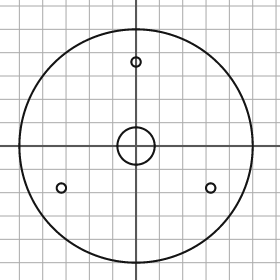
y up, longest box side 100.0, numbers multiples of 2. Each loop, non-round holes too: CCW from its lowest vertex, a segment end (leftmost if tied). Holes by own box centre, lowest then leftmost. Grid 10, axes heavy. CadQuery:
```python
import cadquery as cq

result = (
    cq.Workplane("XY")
    .moveTo(0.0, 0.0)
    .circle(50.0)
    .moveTo(-32.0, -18.0)
    .circle(2.0)
    .moveTo(32.0, -18.0)
    .circle(2.0)
    .moveTo(0.0, 0.0)
    .circle(8.0)
    .moveTo(0.0, 36.0)
    .circle(2.0)
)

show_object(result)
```